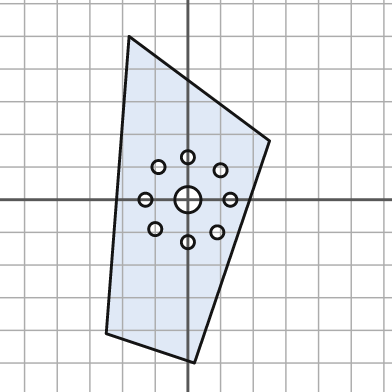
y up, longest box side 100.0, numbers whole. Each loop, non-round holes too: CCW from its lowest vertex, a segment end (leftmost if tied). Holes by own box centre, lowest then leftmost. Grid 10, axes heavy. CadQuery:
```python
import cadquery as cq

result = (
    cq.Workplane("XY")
    .moveTo(2.0, -50.0)
    .lineTo(25.0, 18.0)
    .lineTo(-18.0, 50.0)
    .lineTo(-25.0, -41.0)
    .close()
    .moveTo(0.0, -13.0)
    .circle(2.0)
    .moveTo(9.0, -10.0)
    .circle(2.0)
    .moveTo(-10.0, -9.0)
    .circle(2.0)
    .moveTo(-13.0, 0.0)
    .circle(2.0)
    .moveTo(0.0, 0.0)
    .circle(4.0)
    .moveTo(13.0, 0.0)
    .circle(2.0)
    .moveTo(10.0, 9.0)
    .circle(2.0)
    .moveTo(-9.0, 10.0)
    .circle(2.0)
    .moveTo(0.0, 13.0)
    .circle(2.0)
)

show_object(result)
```